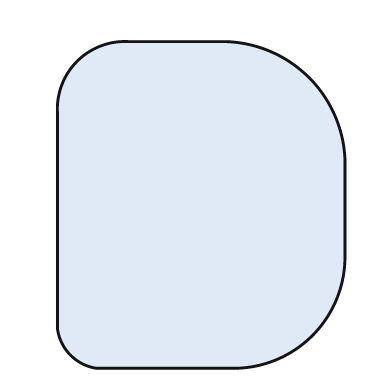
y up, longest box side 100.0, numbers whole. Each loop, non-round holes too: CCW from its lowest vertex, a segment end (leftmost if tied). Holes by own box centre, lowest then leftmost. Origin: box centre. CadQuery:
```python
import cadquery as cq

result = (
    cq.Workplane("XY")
    .moveTo(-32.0, -50.0)
    .lineTo(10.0, -50.0)
    .threePointArc((34.0, -40.0), (44.0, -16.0))
    .lineTo(44.0, 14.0)
    .threePointArc((33.0, 39.0), (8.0, 50.0))
    .lineTo(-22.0, 50.0)
    .threePointArc((-38.0, 44.0), (-44.0, 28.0))
    .lineTo(-44.0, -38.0)
    .threePointArc((-40.0, -46.0), (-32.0, -50.0))
    .close()
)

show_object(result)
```